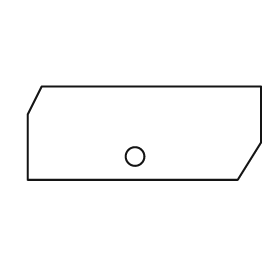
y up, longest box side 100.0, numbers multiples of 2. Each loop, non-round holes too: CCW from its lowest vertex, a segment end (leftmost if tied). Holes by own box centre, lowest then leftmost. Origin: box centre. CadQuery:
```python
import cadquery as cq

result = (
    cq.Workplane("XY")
    .moveTo(-50.0, -20.0)
    .lineTo(40.0, -20.0)
    .lineTo(50.0, -4.0)
    .lineTo(50.0, 20.0)
    .lineTo(-44.0, 20.0)
    .lineTo(-50.0, 8.0)
    .close()
    .moveTo(-4.0, -10.0)
    .circle(4.0)
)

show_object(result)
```